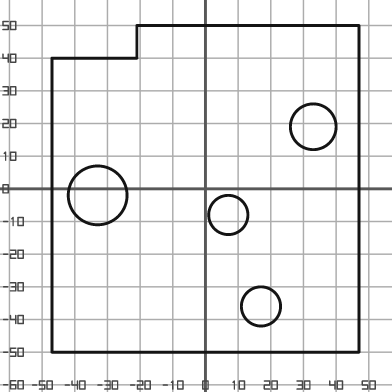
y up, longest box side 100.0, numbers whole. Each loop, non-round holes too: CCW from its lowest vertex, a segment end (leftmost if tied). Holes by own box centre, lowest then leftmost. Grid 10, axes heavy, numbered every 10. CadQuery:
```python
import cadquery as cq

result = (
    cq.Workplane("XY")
    .moveTo(-47.0, -50.0)
    .lineTo(47.0, -50.0)
    .lineTo(47.0, 50.0)
    .lineTo(-21.0, 50.0)
    .lineTo(-21.0, 40.0)
    .lineTo(-47.0, 40.0)
    .close()
    .moveTo(17.0, -36.0)
    .circle(6.0)
    .moveTo(7.0, -8.0)
    .circle(6.0)
    .moveTo(-33.0, -2.0)
    .circle(9.0)
    .moveTo(33.0, 19.0)
    .circle(7.0)
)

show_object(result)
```